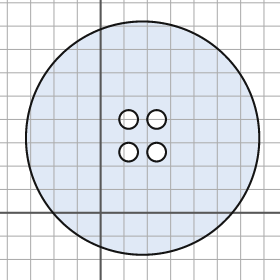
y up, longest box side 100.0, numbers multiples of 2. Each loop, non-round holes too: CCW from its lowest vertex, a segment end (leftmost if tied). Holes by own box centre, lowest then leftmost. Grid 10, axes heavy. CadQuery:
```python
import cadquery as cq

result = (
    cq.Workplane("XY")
    .moveTo(18.0, 32.0)
    .circle(50.0)
    .moveTo(12.0, 26.0)
    .circle(4.0)
    .moveTo(24.0, 26.0)
    .circle(4.0)
    .moveTo(12.0, 40.0)
    .circle(4.0)
    .moveTo(24.0, 40.0)
    .circle(4.0)
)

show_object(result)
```